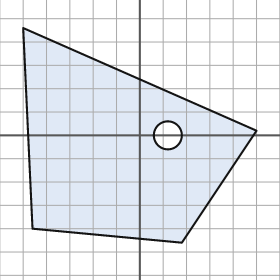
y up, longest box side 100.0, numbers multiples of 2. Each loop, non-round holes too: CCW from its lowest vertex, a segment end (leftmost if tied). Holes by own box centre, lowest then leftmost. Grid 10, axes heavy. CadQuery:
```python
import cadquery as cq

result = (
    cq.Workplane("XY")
    .moveTo(18.0, -46.0)
    .lineTo(50.0, 2.0)
    .lineTo(-50.0, 46.0)
    .lineTo(-46.0, -40.0)
    .close()
    .moveTo(12.0, 0.0)
    .circle(6.0)
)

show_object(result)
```